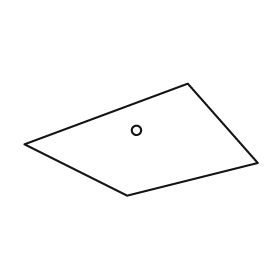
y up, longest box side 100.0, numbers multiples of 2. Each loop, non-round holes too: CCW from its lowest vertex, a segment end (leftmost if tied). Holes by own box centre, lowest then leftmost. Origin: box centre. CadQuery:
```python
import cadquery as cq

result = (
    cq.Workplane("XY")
    .moveTo(-6.0, -24.0)
    .lineTo(50.0, -10.0)
    .lineTo(20.0, 24.0)
    .lineTo(-50.0, -2.0)
    .close()
    .moveTo(-2.0, 4.0)
    .circle(2.0)
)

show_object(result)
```